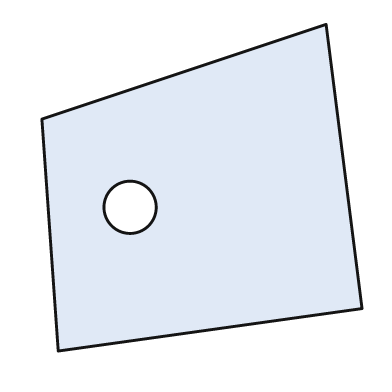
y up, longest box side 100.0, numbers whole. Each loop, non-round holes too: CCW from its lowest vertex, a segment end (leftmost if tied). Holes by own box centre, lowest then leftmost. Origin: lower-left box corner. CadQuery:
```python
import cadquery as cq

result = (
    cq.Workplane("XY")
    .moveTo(5.0, 0.0)
    .lineTo(98.0, 13.0)
    .lineTo(87.0, 100.0)
    .lineTo(0.0, 71.0)
    .close()
    .moveTo(27.0, 44.0)
    .circle(8.0)
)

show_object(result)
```